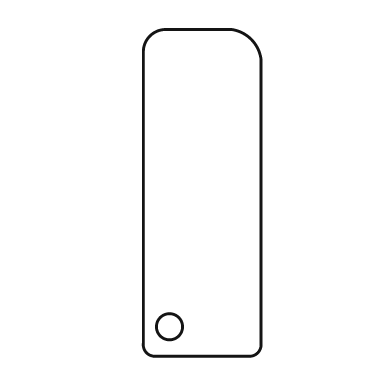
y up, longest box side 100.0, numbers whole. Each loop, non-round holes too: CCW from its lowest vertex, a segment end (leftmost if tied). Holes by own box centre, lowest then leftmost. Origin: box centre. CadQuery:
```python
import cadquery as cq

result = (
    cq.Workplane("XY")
    .moveTo(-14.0, -50.0)
    .lineTo(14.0, -50.0)
    .threePointArc((17.0, -49.0), (18.0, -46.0))
    .lineTo(18.0, 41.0)
    .threePointArc((15.0, 47.0), (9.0, 50.0))
    .lineTo(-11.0, 50.0)
    .threePointArc((-16.0, 48.0), (-18.0, 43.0))
    .lineTo(-18.0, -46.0)
    .threePointArc((-17.0, -49.0), (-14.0, -50.0))
    .close()
    .moveTo(-10.0, -41.0)
    .circle(4.0)
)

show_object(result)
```